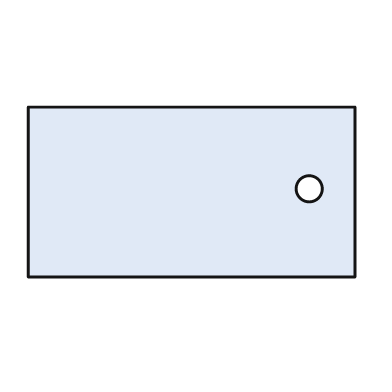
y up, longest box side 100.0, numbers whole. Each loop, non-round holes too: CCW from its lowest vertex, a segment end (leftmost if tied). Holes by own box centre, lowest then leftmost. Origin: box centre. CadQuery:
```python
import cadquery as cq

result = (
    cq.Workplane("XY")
    .moveTo(-50.0, -26.0)
    .lineTo(50.0, -26.0)
    .lineTo(50.0, 26.0)
    .lineTo(-50.0, 26.0)
    .close()
    .moveTo(36.0, 1.0)
    .circle(4.0)
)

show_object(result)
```